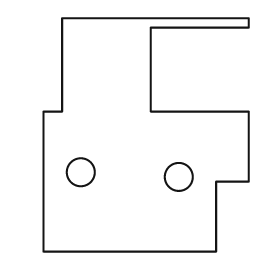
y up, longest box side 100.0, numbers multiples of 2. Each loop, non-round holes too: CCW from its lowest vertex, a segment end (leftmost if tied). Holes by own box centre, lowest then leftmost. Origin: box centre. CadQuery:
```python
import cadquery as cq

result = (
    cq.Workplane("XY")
    .moveTo(-44.0, -50.0)
    .lineTo(30.0, -50.0)
    .lineTo(30.0, -20.0)
    .lineTo(44.0, -20.0)
    .lineTo(44.0, 10.0)
    .lineTo(2.0, 10.0)
    .lineTo(2.0, 46.0)
    .lineTo(44.0, 46.0)
    .lineTo(44.0, 50.0)
    .lineTo(-36.0, 50.0)
    .lineTo(-36.0, 10.0)
    .lineTo(-44.0, 10.0)
    .close()
    .moveTo(14.0, -18.0)
    .circle(6.0)
    .moveTo(-28.0, -16.0)
    .circle(6.0)
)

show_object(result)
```